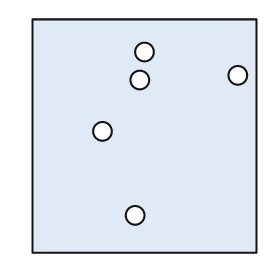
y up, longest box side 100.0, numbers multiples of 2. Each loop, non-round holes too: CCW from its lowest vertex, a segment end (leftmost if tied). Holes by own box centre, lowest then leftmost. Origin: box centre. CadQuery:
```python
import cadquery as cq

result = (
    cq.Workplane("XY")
    .moveTo(-48.0, -50.0)
    .lineTo(48.0, -50.0)
    .lineTo(48.0, 50.0)
    .lineTo(-48.0, 50.0)
    .close()
    .moveTo(-4.0, -34.0)
    .circle(4.0)
    .moveTo(-18.0, 2.0)
    .circle(4.0)
    .moveTo(-2.0, 24.0)
    .circle(4.0)
    .moveTo(40.0, 26.0)
    .circle(4.0)
    .moveTo(0.0, 36.0)
    .circle(4.0)
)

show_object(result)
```